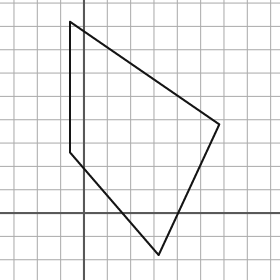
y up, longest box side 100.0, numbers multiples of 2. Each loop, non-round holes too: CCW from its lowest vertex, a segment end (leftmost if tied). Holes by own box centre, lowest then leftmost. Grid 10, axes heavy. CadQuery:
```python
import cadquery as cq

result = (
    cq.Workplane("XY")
    .moveTo(32.0, -18.0)
    .lineTo(58.0, 38.0)
    .lineTo(-6.0, 82.0)
    .lineTo(-6.0, 26.0)
    .close()
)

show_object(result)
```